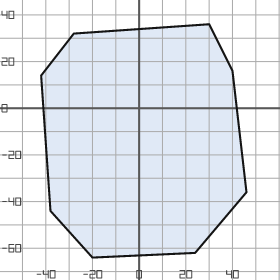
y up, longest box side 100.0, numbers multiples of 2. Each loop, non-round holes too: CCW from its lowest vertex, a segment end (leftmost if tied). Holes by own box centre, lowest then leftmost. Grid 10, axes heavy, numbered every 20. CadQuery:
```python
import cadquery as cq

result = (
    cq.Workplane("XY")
    .moveTo(-20.0, -64.0)
    .lineTo(24.0, -62.0)
    .lineTo(46.0, -36.0)
    .lineTo(40.0, 16.0)
    .lineTo(30.0, 36.0)
    .lineTo(-28.0, 32.0)
    .lineTo(-42.0, 14.0)
    .lineTo(-38.0, -44.0)
    .close()
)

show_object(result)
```